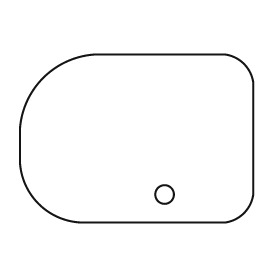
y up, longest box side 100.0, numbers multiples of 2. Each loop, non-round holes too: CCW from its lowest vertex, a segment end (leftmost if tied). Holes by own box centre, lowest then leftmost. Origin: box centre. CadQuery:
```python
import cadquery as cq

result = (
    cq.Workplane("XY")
    .moveTo(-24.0, -36.0)
    .lineTo(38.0, -36.0)
    .threePointArc((46.0, -32.0), (50.0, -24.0))
    .lineTo(50.0, 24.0)
    .threePointArc((46.0, 32.0), (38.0, 36.0))
    .lineTo(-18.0, 36.0)
    .threePointArc((-40.0, 26.0), (-50.0, 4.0))
    .lineTo(-50.0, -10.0)
    .threePointArc((-42.0, -28.0), (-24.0, -36.0))
    .close()
    .moveTo(12.0, -24.0)
    .circle(4.0)
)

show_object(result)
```